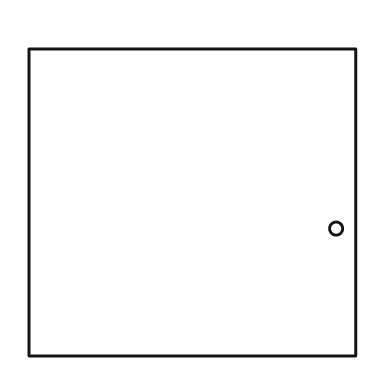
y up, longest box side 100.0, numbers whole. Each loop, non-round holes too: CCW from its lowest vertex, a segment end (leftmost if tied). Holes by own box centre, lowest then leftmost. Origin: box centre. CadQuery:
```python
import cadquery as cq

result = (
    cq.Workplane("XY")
    .moveTo(-50.0, -47.0)
    .lineTo(50.0, -47.0)
    .lineTo(50.0, 47.0)
    .lineTo(-50.0, 47.0)
    .close()
    .moveTo(44.0, -8.0)
    .circle(2.0)
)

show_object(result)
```